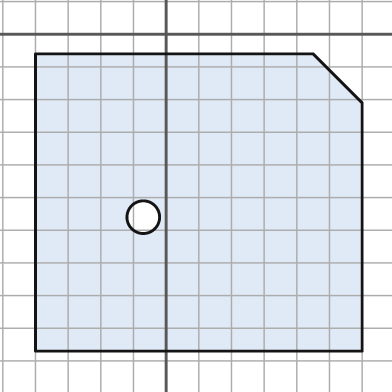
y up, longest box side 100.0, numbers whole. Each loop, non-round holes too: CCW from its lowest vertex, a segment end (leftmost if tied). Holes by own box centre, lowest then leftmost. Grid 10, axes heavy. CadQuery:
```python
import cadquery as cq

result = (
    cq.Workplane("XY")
    .moveTo(-40.0, -97.0)
    .lineTo(60.0, -97.0)
    .lineTo(60.0, -21.0)
    .lineTo(45.0, -6.0)
    .lineTo(-40.0, -6.0)
    .close()
    .moveTo(-7.0, -56.0)
    .circle(5.0)
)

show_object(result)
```